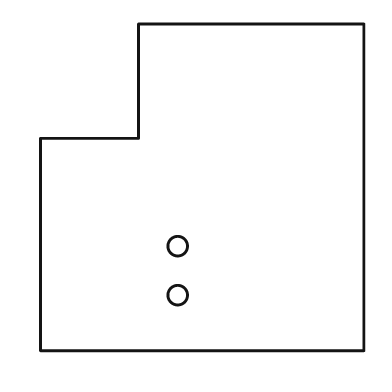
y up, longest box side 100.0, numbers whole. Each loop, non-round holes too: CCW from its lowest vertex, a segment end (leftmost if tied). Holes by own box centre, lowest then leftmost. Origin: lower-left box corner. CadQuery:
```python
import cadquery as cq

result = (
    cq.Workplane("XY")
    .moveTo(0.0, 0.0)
    .lineTo(99.0, 0.0)
    .lineTo(99.0, 100.0)
    .lineTo(30.0, 100.0)
    .lineTo(30.0, 65.0)
    .lineTo(0.0, 65.0)
    .close()
    .moveTo(42.0, 17.0)
    .circle(3.0)
    .moveTo(42.0, 32.0)
    .circle(3.0)
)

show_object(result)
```